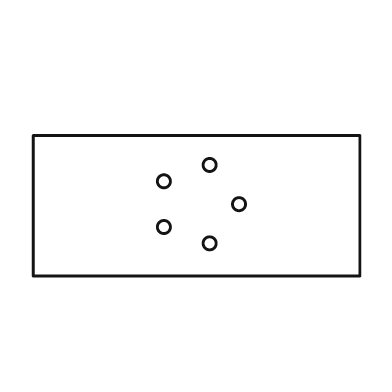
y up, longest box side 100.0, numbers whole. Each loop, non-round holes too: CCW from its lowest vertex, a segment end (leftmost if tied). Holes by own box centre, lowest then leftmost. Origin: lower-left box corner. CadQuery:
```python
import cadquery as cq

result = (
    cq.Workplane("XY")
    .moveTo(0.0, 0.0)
    .lineTo(100.0, 0.0)
    .lineTo(100.0, 43.0)
    .lineTo(0.0, 43.0)
    .close()
    .moveTo(54.0, 10.0)
    .circle(2.0)
    .moveTo(40.0, 15.0)
    .circle(2.0)
    .moveTo(63.0, 22.0)
    .circle(2.0)
    .moveTo(40.0, 29.0)
    .circle(2.0)
    .moveTo(54.0, 34.0)
    .circle(2.0)
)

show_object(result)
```